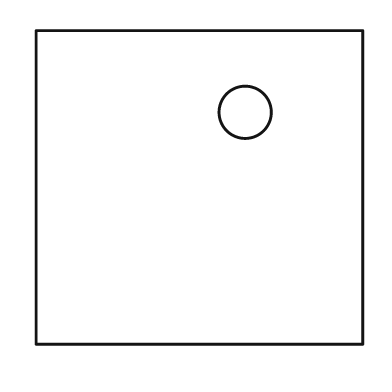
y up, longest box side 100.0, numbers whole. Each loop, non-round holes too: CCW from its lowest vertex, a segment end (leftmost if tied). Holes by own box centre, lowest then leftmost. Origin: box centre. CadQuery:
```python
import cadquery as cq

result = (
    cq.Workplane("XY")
    .moveTo(-50.0, -48.0)
    .lineTo(50.0, -48.0)
    .lineTo(50.0, 48.0)
    .lineTo(-50.0, 48.0)
    .close()
    .moveTo(14.0, 23.0)
    .circle(8.0)
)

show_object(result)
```